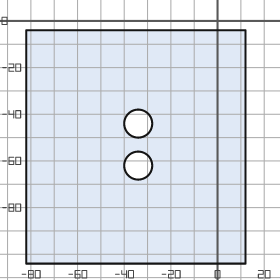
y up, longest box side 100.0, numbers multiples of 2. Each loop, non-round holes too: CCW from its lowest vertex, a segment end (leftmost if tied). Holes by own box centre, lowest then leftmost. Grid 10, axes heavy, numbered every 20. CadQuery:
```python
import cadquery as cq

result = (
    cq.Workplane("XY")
    .moveTo(-82.0, -104.0)
    .lineTo(12.0, -104.0)
    .lineTo(12.0, -4.0)
    .lineTo(-82.0, -4.0)
    .close()
    .moveTo(-34.0, -62.0)
    .circle(6.0)
    .moveTo(-34.0, -44.0)
    .circle(6.0)
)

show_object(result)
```